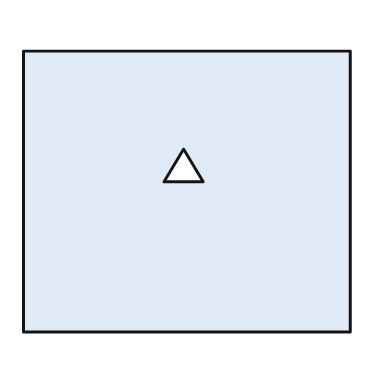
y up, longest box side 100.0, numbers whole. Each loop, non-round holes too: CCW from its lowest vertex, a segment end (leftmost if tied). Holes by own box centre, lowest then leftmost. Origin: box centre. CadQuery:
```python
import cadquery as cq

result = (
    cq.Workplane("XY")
    .moveTo(-50.0, -43.0)
    .lineTo(50.0, -43.0)
    .lineTo(50.0, 43.0)
    .lineTo(-50.0, 43.0)
    .close()
    .moveTo(-7.0, 3.0)
    .lineTo(5.0, 3.0)
    .lineTo(-1.0, 13.0)
    .close()
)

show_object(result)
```